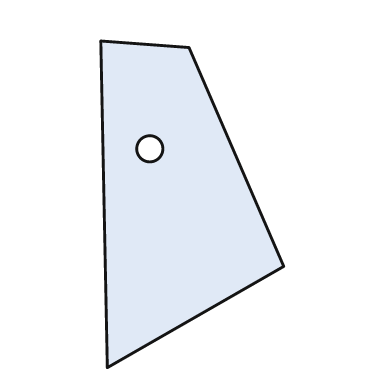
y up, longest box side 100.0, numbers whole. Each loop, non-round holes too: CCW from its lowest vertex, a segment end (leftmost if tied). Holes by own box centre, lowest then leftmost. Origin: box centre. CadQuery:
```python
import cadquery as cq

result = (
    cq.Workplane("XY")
    .moveTo(-26.0, -50.0)
    .lineTo(28.0, -19.0)
    .lineTo(-1.0, 48.0)
    .lineTo(-28.0, 50.0)
    .close()
    .moveTo(-13.0, 17.0)
    .circle(4.0)
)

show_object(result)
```